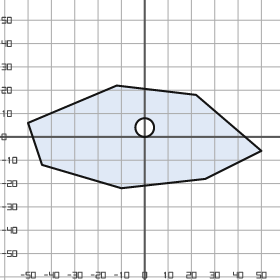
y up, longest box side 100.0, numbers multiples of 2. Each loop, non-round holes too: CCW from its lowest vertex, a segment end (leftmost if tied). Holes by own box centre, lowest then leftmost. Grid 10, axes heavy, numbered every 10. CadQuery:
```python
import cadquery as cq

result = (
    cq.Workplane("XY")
    .moveTo(-10.0, -22.0)
    .lineTo(26.0, -18.0)
    .lineTo(50.0, -6.0)
    .lineTo(22.0, 18.0)
    .lineTo(-12.0, 22.0)
    .lineTo(-50.0, 6.0)
    .lineTo(-44.0, -12.0)
    .close()
    .moveTo(0.0, 4.0)
    .circle(4.0)
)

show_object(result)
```